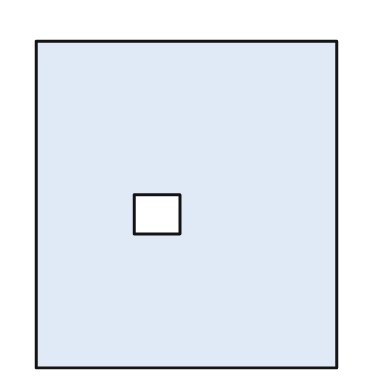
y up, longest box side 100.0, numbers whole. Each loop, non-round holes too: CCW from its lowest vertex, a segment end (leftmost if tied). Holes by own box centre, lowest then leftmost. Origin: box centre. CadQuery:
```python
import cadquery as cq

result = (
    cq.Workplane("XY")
    .moveTo(-46.0, -50.0)
    .lineTo(46.0, -50.0)
    .lineTo(46.0, 50.0)
    .lineTo(-46.0, 50.0)
    .close()
    .moveTo(-16.0, -9.0)
    .lineTo(-2.0, -9.0)
    .lineTo(-2.0, 3.0)
    .lineTo(-16.0, 3.0)
    .close()
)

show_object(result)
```